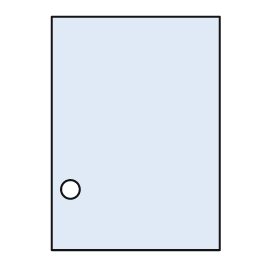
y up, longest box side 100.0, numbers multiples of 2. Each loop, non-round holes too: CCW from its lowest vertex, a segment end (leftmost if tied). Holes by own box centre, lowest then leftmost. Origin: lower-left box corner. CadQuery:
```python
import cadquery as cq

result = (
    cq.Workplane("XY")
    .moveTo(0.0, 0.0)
    .lineTo(72.0, 0.0)
    .lineTo(72.0, 100.0)
    .lineTo(0.0, 100.0)
    .close()
    .moveTo(8.0, 26.0)
    .circle(4.0)
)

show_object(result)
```